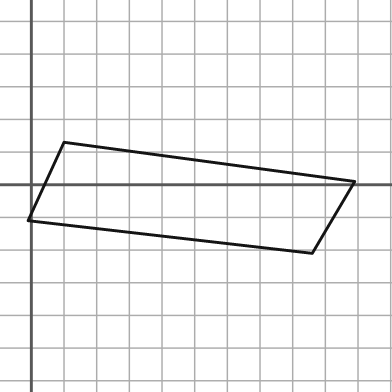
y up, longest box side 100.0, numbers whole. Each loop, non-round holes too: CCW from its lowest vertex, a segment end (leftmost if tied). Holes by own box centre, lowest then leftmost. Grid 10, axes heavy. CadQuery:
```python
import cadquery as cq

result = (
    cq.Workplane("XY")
    .moveTo(86.0, -21.0)
    .lineTo(99.0, 1.0)
    .lineTo(10.0, 13.0)
    .lineTo(-1.0, -11.0)
    .close()
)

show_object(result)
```